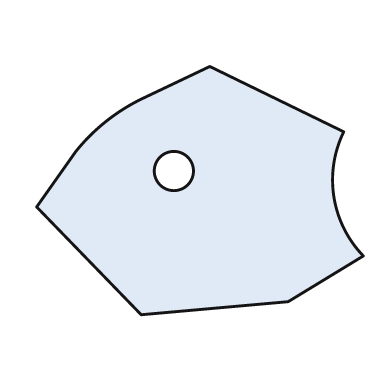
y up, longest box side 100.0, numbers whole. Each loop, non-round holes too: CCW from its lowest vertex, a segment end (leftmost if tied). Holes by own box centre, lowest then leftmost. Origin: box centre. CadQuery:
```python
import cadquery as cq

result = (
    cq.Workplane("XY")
    .moveTo(-18.0, -38.0)
    .lineTo(27.0, -34.0)
    .lineTo(50.0, -20.0)
    .threePointArc((41.0, -2.0), (44.0, 18.0))
    .lineTo(3.0, 38.0)
    .lineTo(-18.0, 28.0)
    .threePointArc((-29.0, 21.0), (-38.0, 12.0))
    .lineTo(-50.0, -5.0)
    .close()
    .moveTo(-8.0, 6.0)
    .circle(6.0)
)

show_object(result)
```